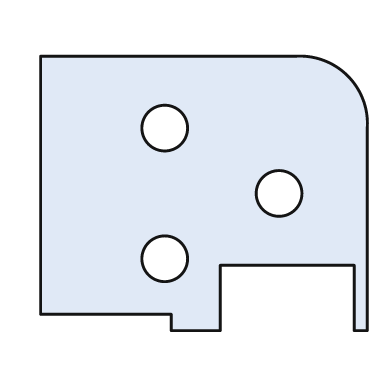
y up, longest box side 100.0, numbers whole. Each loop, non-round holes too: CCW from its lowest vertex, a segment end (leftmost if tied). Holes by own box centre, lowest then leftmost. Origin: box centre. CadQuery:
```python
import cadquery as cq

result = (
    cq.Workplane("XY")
    .moveTo(-10.0, -42.0)
    .lineTo(5.0, -42.0)
    .lineTo(5.0, -22.0)
    .lineTo(46.0, -22.0)
    .lineTo(46.0, -42.0)
    .lineTo(50.0, -42.0)
    .lineTo(50.0, 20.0)
    .threePointArc((44.0, 36.0), (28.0, 42.0))
    .lineTo(-50.0, 42.0)
    .lineTo(-50.0, -37.0)
    .lineTo(-10.0, -37.0)
    .close()
    .moveTo(-12.0, -20.0)
    .circle(7.0)
    .moveTo(23.0, 0.0)
    .circle(7.0)
    .moveTo(-12.0, 20.0)
    .circle(7.0)
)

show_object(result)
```